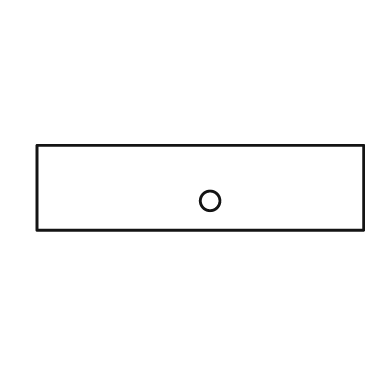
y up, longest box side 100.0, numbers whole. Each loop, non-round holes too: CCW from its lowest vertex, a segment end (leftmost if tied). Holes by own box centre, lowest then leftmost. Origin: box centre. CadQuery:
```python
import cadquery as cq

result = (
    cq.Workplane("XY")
    .moveTo(-50.0, -13.0)
    .lineTo(50.0, -13.0)
    .lineTo(50.0, 13.0)
    .lineTo(-50.0, 13.0)
    .close()
    .moveTo(3.0, -4.0)
    .circle(3.0)
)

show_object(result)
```